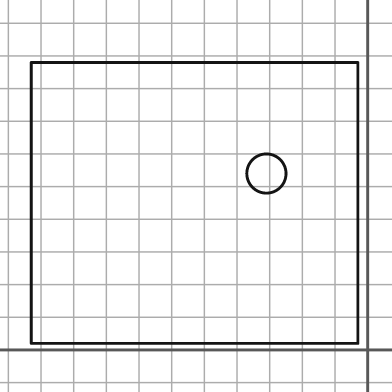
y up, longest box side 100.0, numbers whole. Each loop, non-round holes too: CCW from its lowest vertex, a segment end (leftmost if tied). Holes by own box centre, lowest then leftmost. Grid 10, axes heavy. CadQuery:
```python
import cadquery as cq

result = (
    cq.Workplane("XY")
    .moveTo(-103.0, 2.0)
    .lineTo(-3.0, 2.0)
    .lineTo(-3.0, 88.0)
    .lineTo(-103.0, 88.0)
    .close()
    .moveTo(-31.0, 54.0)
    .circle(6.0)
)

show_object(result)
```